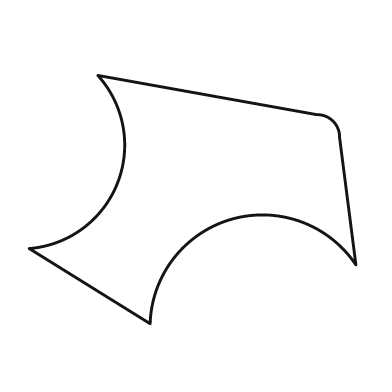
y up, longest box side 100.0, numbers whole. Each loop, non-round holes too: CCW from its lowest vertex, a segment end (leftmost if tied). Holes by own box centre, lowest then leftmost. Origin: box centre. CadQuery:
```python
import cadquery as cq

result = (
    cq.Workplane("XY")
    .moveTo(-13.0, -38.0)
    .threePointArc((12.0, -6.0), (50.0, -20.0))
    .lineTo(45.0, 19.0)
    .threePointArc((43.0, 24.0), (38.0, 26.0))
    .lineTo(-29.0, 38.0)
    .threePointArc((-23.0, 5.0), (-50.0, -15.0))
    .close()
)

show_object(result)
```